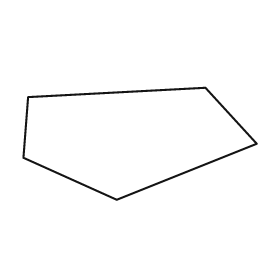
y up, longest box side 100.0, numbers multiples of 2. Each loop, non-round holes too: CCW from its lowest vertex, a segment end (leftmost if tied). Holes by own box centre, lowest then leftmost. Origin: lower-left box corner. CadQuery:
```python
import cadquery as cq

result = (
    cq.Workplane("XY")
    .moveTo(40.0, 0.0)
    .lineTo(100.0, 24.0)
    .lineTo(78.0, 48.0)
    .lineTo(2.0, 44.0)
    .lineTo(0.0, 18.0)
    .close()
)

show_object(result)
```